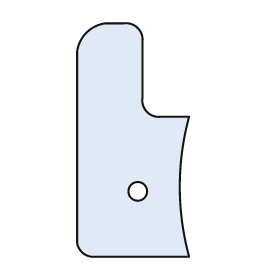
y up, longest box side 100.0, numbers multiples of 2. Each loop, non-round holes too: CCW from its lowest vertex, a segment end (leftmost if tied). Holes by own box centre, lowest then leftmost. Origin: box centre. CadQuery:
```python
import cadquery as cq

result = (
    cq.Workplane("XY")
    .moveTo(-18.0, -50.0)
    .lineTo(24.0, -50.0)
    .threePointArc((20.0, -20.0), (24.0, 10.0))
    .lineTo(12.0, 10.0)
    .threePointArc((6.0, 12.0), (4.0, 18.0))
    .lineTo(4.0, 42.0)
    .threePointArc((2.0, 48.0), (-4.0, 50.0))
    .lineTo(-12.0, 50.0)
    .threePointArc((-20.0, 46.0), (-24.0, 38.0))
    .lineTo(-24.0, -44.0)
    .threePointArc((-22.0, -48.0), (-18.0, -50.0))
    .close()
    .moveTo(2.0, -22.0)
    .circle(4.0)
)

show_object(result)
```